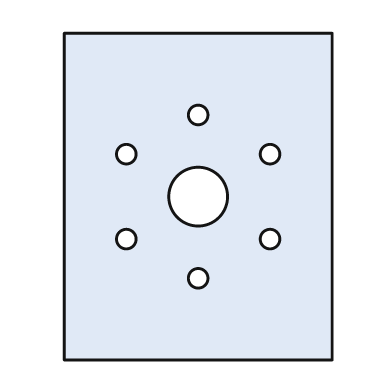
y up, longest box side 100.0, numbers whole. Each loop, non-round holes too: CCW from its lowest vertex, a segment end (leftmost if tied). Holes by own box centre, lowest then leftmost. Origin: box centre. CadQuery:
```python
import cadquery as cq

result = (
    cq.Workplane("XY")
    .moveTo(-41.0, -50.0)
    .lineTo(41.0, -50.0)
    .lineTo(41.0, 50.0)
    .lineTo(-41.0, 50.0)
    .close()
    .moveTo(0.0, -25.0)
    .circle(3.0)
    .moveTo(-22.0, -13.0)
    .circle(3.0)
    .moveTo(22.0, -13.0)
    .circle(3.0)
    .moveTo(0.0, 0.0)
    .circle(9.0)
    .moveTo(-22.0, 13.0)
    .circle(3.0)
    .moveTo(22.0, 13.0)
    .circle(3.0)
    .moveTo(0.0, 25.0)
    .circle(3.0)
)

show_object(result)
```